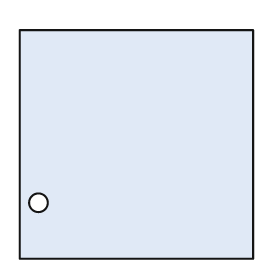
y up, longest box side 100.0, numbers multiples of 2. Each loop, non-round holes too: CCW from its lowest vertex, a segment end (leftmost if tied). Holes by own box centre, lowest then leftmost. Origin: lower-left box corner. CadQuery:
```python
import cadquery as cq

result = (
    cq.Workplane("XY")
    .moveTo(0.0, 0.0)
    .lineTo(100.0, 0.0)
    .lineTo(100.0, 98.0)
    .lineTo(0.0, 98.0)
    .close()
    .moveTo(8.0, 24.0)
    .circle(4.0)
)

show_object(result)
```